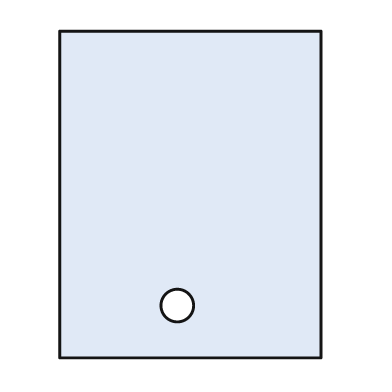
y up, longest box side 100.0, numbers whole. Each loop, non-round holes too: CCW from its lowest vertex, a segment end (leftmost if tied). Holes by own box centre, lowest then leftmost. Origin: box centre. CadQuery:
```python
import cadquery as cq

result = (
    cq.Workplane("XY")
    .moveTo(-40.0, -50.0)
    .lineTo(40.0, -50.0)
    .lineTo(40.0, 50.0)
    .lineTo(-40.0, 50.0)
    .close()
    .moveTo(-4.0, -34.0)
    .circle(5.0)
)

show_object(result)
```